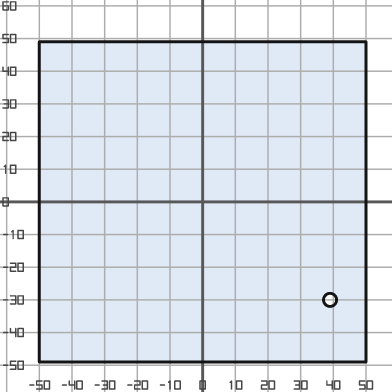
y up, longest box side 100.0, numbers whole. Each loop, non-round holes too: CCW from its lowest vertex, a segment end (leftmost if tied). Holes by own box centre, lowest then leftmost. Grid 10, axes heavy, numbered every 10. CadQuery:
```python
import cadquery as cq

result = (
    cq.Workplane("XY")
    .moveTo(-50.0, -49.0)
    .lineTo(50.0, -49.0)
    .lineTo(50.0, 49.0)
    .lineTo(-50.0, 49.0)
    .close()
    .moveTo(39.0, -30.0)
    .circle(2.0)
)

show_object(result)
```